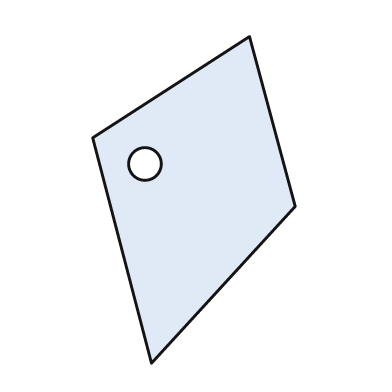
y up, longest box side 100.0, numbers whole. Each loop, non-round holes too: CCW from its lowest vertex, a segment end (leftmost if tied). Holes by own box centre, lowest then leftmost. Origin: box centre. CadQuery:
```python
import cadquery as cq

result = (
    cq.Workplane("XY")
    .moveTo(-13.0, -50.0)
    .lineTo(31.0, -2.0)
    .lineTo(17.0, 50.0)
    .lineTo(-31.0, 19.0)
    .close()
    .moveTo(-15.0, 11.0)
    .circle(5.0)
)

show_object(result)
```